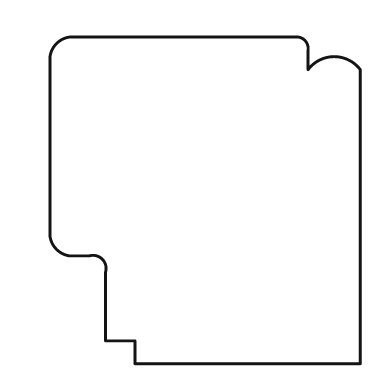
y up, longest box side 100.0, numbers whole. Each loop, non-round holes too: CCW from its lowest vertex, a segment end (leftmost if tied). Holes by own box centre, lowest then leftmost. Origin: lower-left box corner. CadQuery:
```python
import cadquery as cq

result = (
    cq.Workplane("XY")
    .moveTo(26.0, 0.0)
    .lineTo(95.0, 0.0)
    .lineTo(95.0, 90.0)
    .threePointArc((87.0, 94.0), (79.0, 90.0))
    .lineTo(79.0, 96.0)
    .threePointArc((78.0, 99.0), (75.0, 100.0))
    .lineTo(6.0, 100.0)
    .threePointArc((2.0, 98.0), (0.0, 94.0))
    .lineTo(0.0, 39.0)
    .threePointArc((2.0, 35.0), (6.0, 33.0))
    .lineTo(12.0, 33.0)
    .threePointArc((16.0, 32.0), (17.0, 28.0))
    .lineTo(17.0, 7.0)
    .lineTo(26.0, 7.0)
    .close()
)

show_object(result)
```